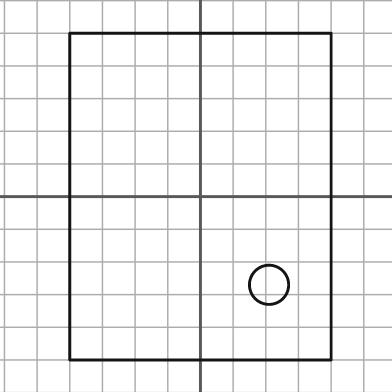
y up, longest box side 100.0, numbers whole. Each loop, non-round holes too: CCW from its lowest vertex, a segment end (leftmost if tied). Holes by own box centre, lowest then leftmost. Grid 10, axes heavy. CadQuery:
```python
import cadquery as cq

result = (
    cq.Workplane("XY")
    .moveTo(-40.0, -50.0)
    .lineTo(40.0, -50.0)
    .lineTo(40.0, 50.0)
    .lineTo(-40.0, 50.0)
    .close()
    .moveTo(21.0, -27.0)
    .circle(6.0)
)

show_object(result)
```